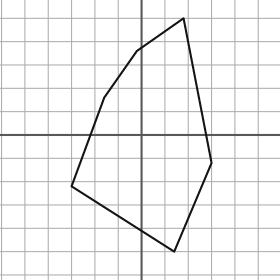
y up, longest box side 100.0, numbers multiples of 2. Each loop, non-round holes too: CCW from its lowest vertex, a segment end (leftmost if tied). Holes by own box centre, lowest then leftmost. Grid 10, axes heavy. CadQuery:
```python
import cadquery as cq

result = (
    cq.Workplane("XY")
    .moveTo(14.0, -50.0)
    .lineTo(30.0, -12.0)
    .lineTo(18.0, 50.0)
    .lineTo(-2.0, 36.0)
    .lineTo(-16.0, 16.0)
    .lineTo(-30.0, -22.0)
    .close()
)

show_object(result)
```